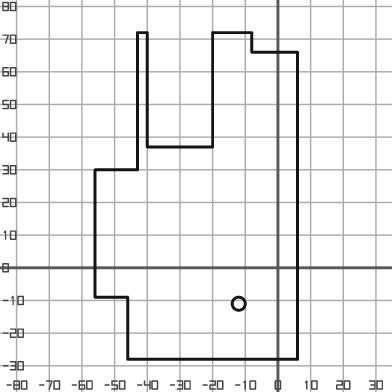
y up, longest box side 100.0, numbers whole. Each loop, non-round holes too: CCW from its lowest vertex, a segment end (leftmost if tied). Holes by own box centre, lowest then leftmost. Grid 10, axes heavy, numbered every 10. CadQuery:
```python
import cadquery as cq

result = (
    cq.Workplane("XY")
    .moveTo(-46.0, -28.0)
    .lineTo(6.0, -28.0)
    .lineTo(6.0, 66.0)
    .lineTo(-8.0, 66.0)
    .lineTo(-8.0, 72.0)
    .lineTo(-20.0, 72.0)
    .lineTo(-20.0, 37.0)
    .lineTo(-40.0, 37.0)
    .lineTo(-40.0, 72.0)
    .lineTo(-43.0, 72.0)
    .lineTo(-43.0, 30.0)
    .lineTo(-56.0, 30.0)
    .lineTo(-56.0, -9.0)
    .lineTo(-46.0, -9.0)
    .close()
    .moveTo(-12.0, -11.0)
    .circle(2.0)
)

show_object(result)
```